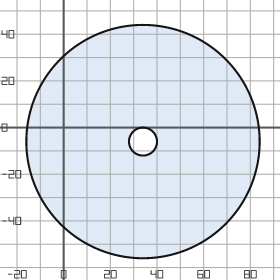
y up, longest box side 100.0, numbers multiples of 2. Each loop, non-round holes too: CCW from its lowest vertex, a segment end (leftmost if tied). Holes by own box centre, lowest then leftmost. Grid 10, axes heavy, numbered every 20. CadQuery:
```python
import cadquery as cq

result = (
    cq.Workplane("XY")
    .moveTo(34.0, -6.0)
    .circle(50.0)
    .moveTo(34.0, -6.0)
    .circle(6.0)
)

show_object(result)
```